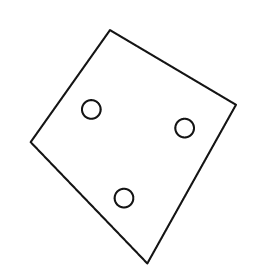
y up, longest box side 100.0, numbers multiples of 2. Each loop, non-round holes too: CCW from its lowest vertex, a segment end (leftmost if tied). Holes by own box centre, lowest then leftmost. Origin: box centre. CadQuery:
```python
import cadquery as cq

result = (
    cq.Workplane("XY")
    .moveTo(6.0, -50.0)
    .lineTo(44.0, 18.0)
    .lineTo(-10.0, 50.0)
    .lineTo(-44.0, 2.0)
    .close()
    .moveTo(-4.0, -22.0)
    .circle(4.0)
    .moveTo(22.0, 8.0)
    .circle(4.0)
    .moveTo(-18.0, 16.0)
    .circle(4.0)
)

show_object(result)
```